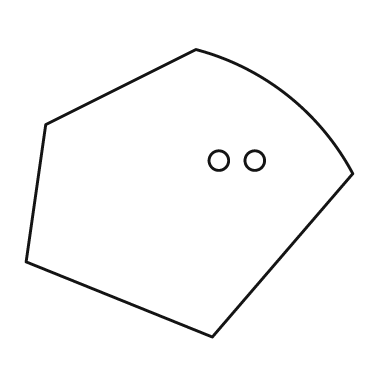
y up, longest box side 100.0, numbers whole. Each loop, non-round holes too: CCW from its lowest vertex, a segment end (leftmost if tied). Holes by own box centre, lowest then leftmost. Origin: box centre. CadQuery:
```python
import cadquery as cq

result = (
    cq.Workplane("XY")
    .moveTo(7.0, -44.0)
    .lineTo(50.0, 6.0)
    .threePointArc((30.0, 30.0), (2.0, 44.0))
    .lineTo(-44.0, 21.0)
    .lineTo(-50.0, -21.0)
    .close()
    .moveTo(9.0, 10.0)
    .circle(3.0)
    .moveTo(20.0, 10.0)
    .circle(3.0)
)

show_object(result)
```